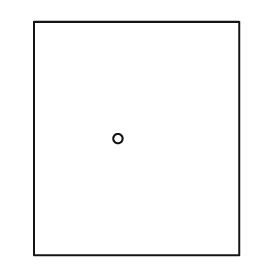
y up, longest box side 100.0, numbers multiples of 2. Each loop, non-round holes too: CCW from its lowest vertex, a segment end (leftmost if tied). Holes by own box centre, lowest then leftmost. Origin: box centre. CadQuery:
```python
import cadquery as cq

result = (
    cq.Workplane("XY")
    .moveTo(-44.0, -50.0)
    .lineTo(44.0, -50.0)
    .lineTo(44.0, 50.0)
    .lineTo(-44.0, 50.0)
    .close()
    .moveTo(-8.0, 0.0)
    .circle(2.0)
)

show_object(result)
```